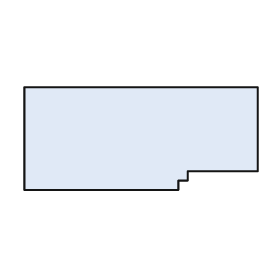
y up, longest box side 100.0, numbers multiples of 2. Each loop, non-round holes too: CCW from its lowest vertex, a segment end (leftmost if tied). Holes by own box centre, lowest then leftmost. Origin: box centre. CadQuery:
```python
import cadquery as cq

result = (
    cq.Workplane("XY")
    .moveTo(-50.0, -22.0)
    .lineTo(16.0, -22.0)
    .lineTo(16.0, -18.0)
    .lineTo(20.0, -18.0)
    .lineTo(20.0, -14.0)
    .lineTo(50.0, -14.0)
    .lineTo(50.0, 22.0)
    .lineTo(-50.0, 22.0)
    .close()
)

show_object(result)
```